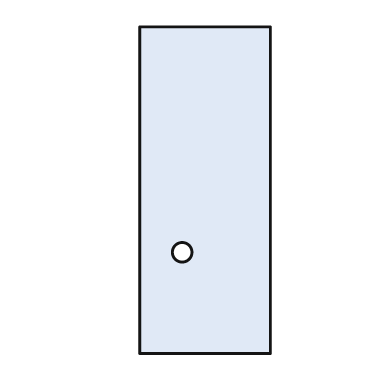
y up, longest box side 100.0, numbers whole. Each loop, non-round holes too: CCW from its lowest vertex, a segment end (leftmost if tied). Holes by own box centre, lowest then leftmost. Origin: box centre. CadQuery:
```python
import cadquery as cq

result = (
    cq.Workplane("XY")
    .moveTo(-20.0, -50.0)
    .lineTo(20.0, -50.0)
    .lineTo(20.0, 50.0)
    .lineTo(-20.0, 50.0)
    .close()
    .moveTo(-7.0, -19.0)
    .circle(3.0)
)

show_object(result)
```